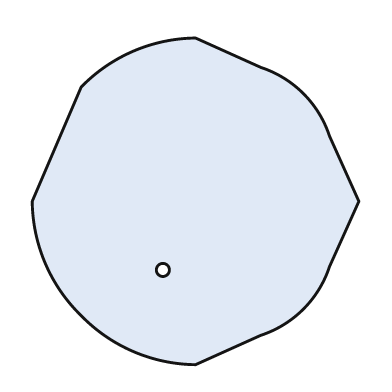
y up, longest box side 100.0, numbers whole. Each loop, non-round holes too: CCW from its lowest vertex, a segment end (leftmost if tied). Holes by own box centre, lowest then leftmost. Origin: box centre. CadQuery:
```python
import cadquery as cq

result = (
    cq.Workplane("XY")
    .moveTo(0.0, -50.0)
    .lineTo(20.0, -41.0)
    .threePointArc((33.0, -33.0), (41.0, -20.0))
    .lineTo(50.0, 0.0)
    .lineTo(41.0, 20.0)
    .threePointArc((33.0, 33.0), (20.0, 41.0))
    .lineTo(0.0, 50.0)
    .threePointArc((-19.0, 46.0), (-35.0, 35.0))
    .lineTo(-50.0, 0.0)
    .threePointArc((-46.0, -19.0), (-35.0, -35.0))
    .threePointArc((-19.0, -46.0), (0.0, -50.0))
    .close()
    .moveTo(-10.0, -21.0)
    .circle(2.0)
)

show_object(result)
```